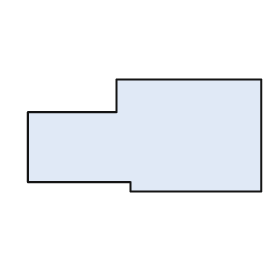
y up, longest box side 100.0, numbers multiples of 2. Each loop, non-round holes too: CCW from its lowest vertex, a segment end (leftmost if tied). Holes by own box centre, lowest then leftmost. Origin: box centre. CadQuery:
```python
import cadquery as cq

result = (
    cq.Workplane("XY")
    .moveTo(-6.0, -24.0)
    .lineTo(50.0, -24.0)
    .lineTo(50.0, 24.0)
    .lineTo(-12.0, 24.0)
    .lineTo(-12.0, 10.0)
    .lineTo(-50.0, 10.0)
    .lineTo(-50.0, -20.0)
    .lineTo(-6.0, -20.0)
    .close()
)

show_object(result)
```